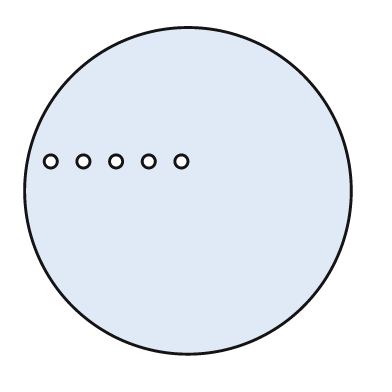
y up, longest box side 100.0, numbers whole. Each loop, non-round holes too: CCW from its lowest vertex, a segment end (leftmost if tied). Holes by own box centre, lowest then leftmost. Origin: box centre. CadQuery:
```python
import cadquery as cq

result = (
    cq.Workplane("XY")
    .moveTo(0.0, 0.0)
    .circle(50.0)
    .moveTo(-42.0, 9.0)
    .circle(2.0)
    .moveTo(-32.0, 9.0)
    .circle(2.0)
    .moveTo(-22.0, 9.0)
    .circle(2.0)
    .moveTo(-12.0, 9.0)
    .circle(2.0)
    .moveTo(-2.0, 9.0)
    .circle(2.0)
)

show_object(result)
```